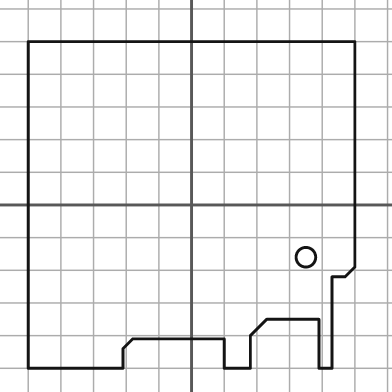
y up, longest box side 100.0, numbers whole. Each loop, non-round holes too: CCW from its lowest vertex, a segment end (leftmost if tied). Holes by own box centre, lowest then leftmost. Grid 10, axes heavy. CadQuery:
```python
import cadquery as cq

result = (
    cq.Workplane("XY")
    .moveTo(-50.0, -50.0)
    .lineTo(-21.0, -50.0)
    .lineTo(-21.0, -44.0)
    .lineTo(-18.0, -41.0)
    .lineTo(10.0, -41.0)
    .lineTo(10.0, -50.0)
    .lineTo(18.0, -50.0)
    .lineTo(18.0, -40.0)
    .lineTo(23.0, -35.0)
    .lineTo(39.0, -35.0)
    .lineTo(39.0, -50.0)
    .lineTo(43.0, -50.0)
    .lineTo(43.0, -22.0)
    .lineTo(47.0, -22.0)
    .lineTo(50.0, -19.0)
    .lineTo(50.0, 50.0)
    .lineTo(-50.0, 50.0)
    .close()
    .moveTo(35.0, -16.0)
    .circle(3.0)
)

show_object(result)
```